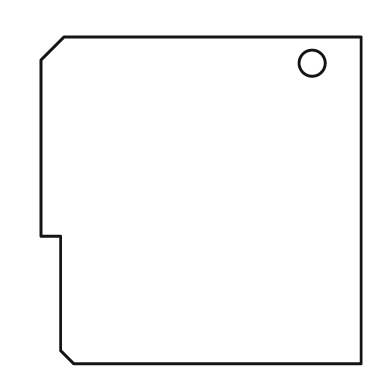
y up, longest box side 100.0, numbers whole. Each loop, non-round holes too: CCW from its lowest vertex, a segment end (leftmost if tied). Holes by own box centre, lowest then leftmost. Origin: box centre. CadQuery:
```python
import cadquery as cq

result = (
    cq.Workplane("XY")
    .moveTo(-39.0, -50.0)
    .lineTo(49.0, -50.0)
    .lineTo(49.0, 50.0)
    .lineTo(-42.0, 50.0)
    .lineTo(-49.0, 43.0)
    .lineTo(-49.0, -11.0)
    .lineTo(-43.0, -11.0)
    .lineTo(-43.0, -46.0)
    .close()
    .moveTo(34.0, 42.0)
    .circle(4.0)
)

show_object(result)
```